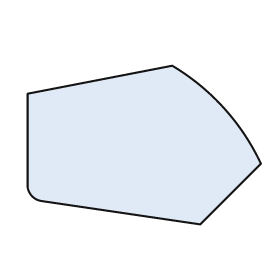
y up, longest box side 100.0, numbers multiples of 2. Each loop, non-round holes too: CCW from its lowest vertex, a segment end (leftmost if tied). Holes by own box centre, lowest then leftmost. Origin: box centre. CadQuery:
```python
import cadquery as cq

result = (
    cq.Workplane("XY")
    .moveTo(24.0, -34.0)
    .lineTo(50.0, -8.0)
    .threePointArc((34.0, 16.0), (12.0, 34.0))
    .lineTo(-50.0, 22.0)
    .lineTo(-50.0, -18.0)
    .threePointArc((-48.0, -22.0), (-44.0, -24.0))
    .close()
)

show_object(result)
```